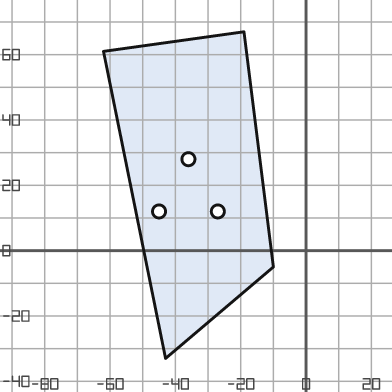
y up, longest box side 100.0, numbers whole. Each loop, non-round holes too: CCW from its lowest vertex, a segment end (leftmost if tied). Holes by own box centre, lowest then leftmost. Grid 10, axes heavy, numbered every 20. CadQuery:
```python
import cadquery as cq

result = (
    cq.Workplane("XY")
    .moveTo(-43.0, -33.0)
    .lineTo(-10.0, -5.0)
    .lineTo(-19.0, 67.0)
    .lineTo(-62.0, 61.0)
    .close()
    .moveTo(-45.0, 12.0)
    .circle(2.0)
    .moveTo(-27.0, 12.0)
    .circle(2.0)
    .moveTo(-36.0, 28.0)
    .circle(2.0)
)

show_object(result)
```